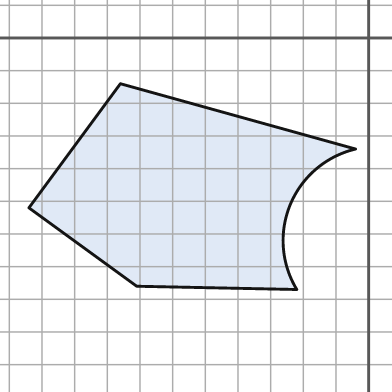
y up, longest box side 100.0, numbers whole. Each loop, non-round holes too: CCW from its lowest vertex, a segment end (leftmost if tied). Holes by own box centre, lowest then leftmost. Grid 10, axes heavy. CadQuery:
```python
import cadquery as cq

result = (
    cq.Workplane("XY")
    .moveTo(-22.0, -77.0)
    .threePointArc((-24.0, -51.0), (-4.0, -34.0))
    .lineTo(-76.0, -14.0)
    .lineTo(-104.0, -52.0)
    .lineTo(-71.0, -76.0)
    .close()
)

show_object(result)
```